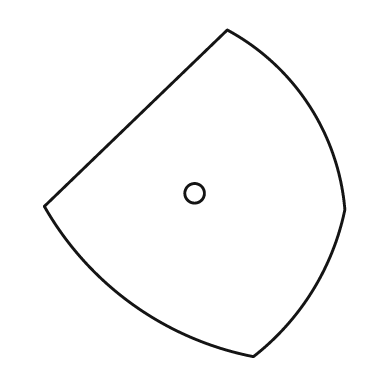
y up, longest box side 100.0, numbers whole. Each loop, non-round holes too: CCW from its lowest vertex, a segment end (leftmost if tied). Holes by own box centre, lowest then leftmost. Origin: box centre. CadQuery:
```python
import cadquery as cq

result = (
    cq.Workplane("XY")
    .moveTo(18.0, -50.0)
    .threePointArc((36.0, -30.0), (46.0, -5.0))
    .threePointArc((35.0, 27.0), (10.0, 50.0))
    .lineTo(-46.0, -4.0)
    .threePointArc((-19.0, -34.0), (18.0, -50.0))
    .close()
    .moveTo(0.0, 0.0)
    .circle(3.0)
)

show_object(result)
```